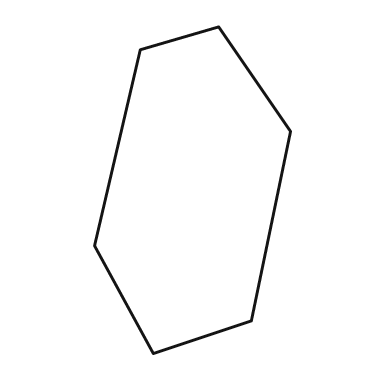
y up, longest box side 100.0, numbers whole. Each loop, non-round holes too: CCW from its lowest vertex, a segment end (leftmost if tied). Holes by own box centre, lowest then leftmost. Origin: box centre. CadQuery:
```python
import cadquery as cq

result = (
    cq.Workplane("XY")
    .moveTo(-12.0, -50.0)
    .lineTo(18.0, -40.0)
    .lineTo(30.0, 18.0)
    .lineTo(8.0, 50.0)
    .lineTo(-16.0, 43.0)
    .lineTo(-30.0, -17.0)
    .close()
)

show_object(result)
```